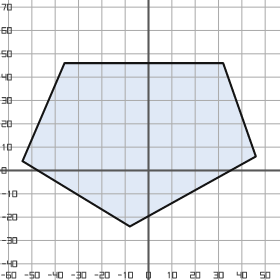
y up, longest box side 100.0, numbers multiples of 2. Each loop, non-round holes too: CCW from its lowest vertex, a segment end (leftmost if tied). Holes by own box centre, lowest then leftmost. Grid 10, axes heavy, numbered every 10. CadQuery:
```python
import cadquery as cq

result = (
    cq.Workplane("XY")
    .moveTo(-8.0, -24.0)
    .lineTo(46.0, 6.0)
    .lineTo(32.0, 46.0)
    .lineTo(-36.0, 46.0)
    .lineTo(-54.0, 4.0)
    .close()
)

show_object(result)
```